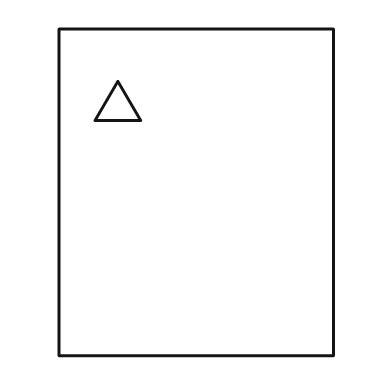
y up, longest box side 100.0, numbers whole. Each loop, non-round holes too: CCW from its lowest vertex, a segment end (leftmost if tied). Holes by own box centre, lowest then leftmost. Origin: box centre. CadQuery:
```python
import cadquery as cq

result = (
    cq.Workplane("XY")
    .moveTo(-42.0, -50.0)
    .lineTo(42.0, -50.0)
    .lineTo(42.0, 50.0)
    .lineTo(-42.0, 50.0)
    .close()
    .moveTo(-31.0, 22.0)
    .lineTo(-17.0, 22.0)
    .lineTo(-24.0, 34.0)
    .close()
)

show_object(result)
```